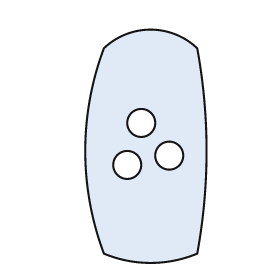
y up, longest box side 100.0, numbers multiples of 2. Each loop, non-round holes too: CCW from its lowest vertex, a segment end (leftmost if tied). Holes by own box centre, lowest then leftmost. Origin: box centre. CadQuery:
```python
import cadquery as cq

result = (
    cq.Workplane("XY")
    .moveTo(-18.0, -46.0)
    .threePointArc((2.0, -50.0), (22.0, -46.0))
    .threePointArc((26.0, -2.0), (22.0, 42.0))
    .threePointArc((2.0, 50.0), (-18.0, 42.0))
    .threePointArc((-26.0, -2.0), (-18.0, -46.0))
    .close()
    .moveTo(-8.0, -8.0)
    .circle(6.0)
    .moveTo(10.0, -4.0)
    .circle(6.0)
    .moveTo(-2.0, 10.0)
    .circle(6.0)
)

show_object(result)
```